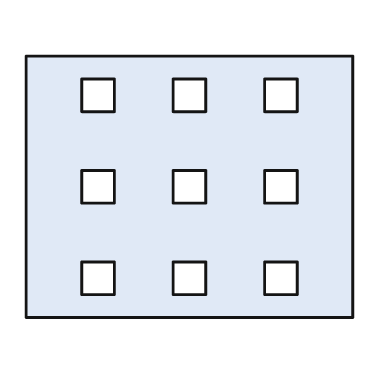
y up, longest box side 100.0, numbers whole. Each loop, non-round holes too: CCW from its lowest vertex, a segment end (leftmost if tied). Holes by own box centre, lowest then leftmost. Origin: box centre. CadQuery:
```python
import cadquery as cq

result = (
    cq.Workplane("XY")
    .moveTo(-50.0, -40.0)
    .lineTo(50.0, -40.0)
    .lineTo(50.0, 40.0)
    .lineTo(-50.0, 40.0)
    .close()
    .moveTo(-33.0, -33.0)
    .lineTo(-23.0, -33.0)
    .lineTo(-23.0, -23.0)
    .lineTo(-33.0, -23.0)
    .close()
    .moveTo(-5.0, -33.0)
    .lineTo(5.0, -33.0)
    .lineTo(5.0, -23.0)
    .lineTo(-5.0, -23.0)
    .close()
    .moveTo(23.0, -33.0)
    .lineTo(33.0, -33.0)
    .lineTo(33.0, -23.0)
    .lineTo(23.0, -23.0)
    .close()
    .moveTo(-33.0, -5.0)
    .lineTo(-23.0, -5.0)
    .lineTo(-23.0, 5.0)
    .lineTo(-33.0, 5.0)
    .close()
    .moveTo(-5.0, -5.0)
    .lineTo(5.0, -5.0)
    .lineTo(5.0, 5.0)
    .lineTo(-5.0, 5.0)
    .close()
    .moveTo(23.0, -5.0)
    .lineTo(33.0, -5.0)
    .lineTo(33.0, 5.0)
    .lineTo(23.0, 5.0)
    .close()
    .moveTo(-33.0, 23.0)
    .lineTo(-23.0, 23.0)
    .lineTo(-23.0, 33.0)
    .lineTo(-33.0, 33.0)
    .close()
    .moveTo(-5.0, 23.0)
    .lineTo(5.0, 23.0)
    .lineTo(5.0, 33.0)
    .lineTo(-5.0, 33.0)
    .close()
    .moveTo(23.0, 23.0)
    .lineTo(33.0, 23.0)
    .lineTo(33.0, 33.0)
    .lineTo(23.0, 33.0)
    .close()
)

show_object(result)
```